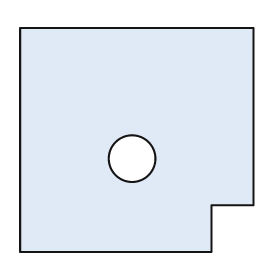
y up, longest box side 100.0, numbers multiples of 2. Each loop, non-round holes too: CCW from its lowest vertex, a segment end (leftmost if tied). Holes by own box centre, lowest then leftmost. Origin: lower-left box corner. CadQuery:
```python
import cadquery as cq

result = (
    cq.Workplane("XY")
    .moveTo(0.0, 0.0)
    .lineTo(82.0, 0.0)
    .lineTo(82.0, 20.0)
    .lineTo(100.0, 20.0)
    .lineTo(100.0, 96.0)
    .lineTo(0.0, 96.0)
    .close()
    .moveTo(48.0, 40.0)
    .circle(10.0)
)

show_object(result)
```